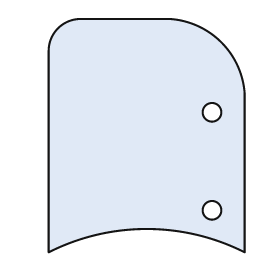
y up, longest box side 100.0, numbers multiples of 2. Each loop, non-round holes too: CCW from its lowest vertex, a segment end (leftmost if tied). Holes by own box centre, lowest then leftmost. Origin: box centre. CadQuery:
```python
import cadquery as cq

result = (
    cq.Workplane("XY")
    .moveTo(-42.0, -50.0)
    .threePointArc((0.0, -40.0), (42.0, -50.0))
    .lineTo(42.0, 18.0)
    .threePointArc((32.0, 40.0), (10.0, 50.0))
    .lineTo(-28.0, 50.0)
    .threePointArc((-38.0, 46.0), (-42.0, 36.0))
    .close()
    .moveTo(28.0, -32.0)
    .circle(4.0)
    .moveTo(28.0, 10.0)
    .circle(4.0)
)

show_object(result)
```